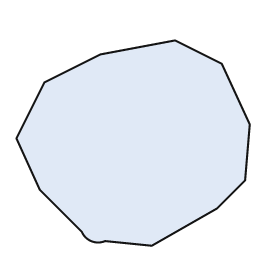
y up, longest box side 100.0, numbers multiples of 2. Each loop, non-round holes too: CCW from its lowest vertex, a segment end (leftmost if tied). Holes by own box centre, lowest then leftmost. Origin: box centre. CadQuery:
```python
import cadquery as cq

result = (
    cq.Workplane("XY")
    .moveTo(8.0, -44.0)
    .lineTo(36.0, -28.0)
    .lineTo(48.0, -16.0)
    .lineTo(50.0, 8.0)
    .lineTo(38.0, 34.0)
    .lineTo(18.0, 44.0)
    .lineTo(-14.0, 38.0)
    .lineTo(-38.0, 26.0)
    .lineTo(-50.0, 2.0)
    .lineTo(-40.0, -20.0)
    .lineTo(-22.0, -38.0)
    .threePointArc((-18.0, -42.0), (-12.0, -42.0))
    .close()
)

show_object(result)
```